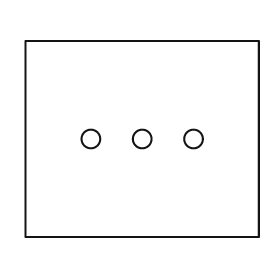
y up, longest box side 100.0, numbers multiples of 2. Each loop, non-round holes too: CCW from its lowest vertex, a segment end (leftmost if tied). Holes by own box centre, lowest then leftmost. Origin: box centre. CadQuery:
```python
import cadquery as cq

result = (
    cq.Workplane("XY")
    .moveTo(-50.0, -42.0)
    .lineTo(50.0, -42.0)
    .lineTo(50.0, 42.0)
    .lineTo(-50.0, 42.0)
    .close()
    .moveTo(-22.0, 0.0)
    .circle(4.0)
    .moveTo(0.0, 0.0)
    .circle(4.0)
    .moveTo(22.0, 0.0)
    .circle(4.0)
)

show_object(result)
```